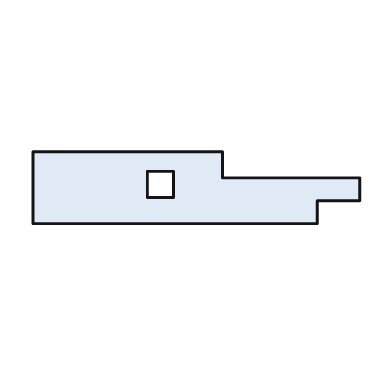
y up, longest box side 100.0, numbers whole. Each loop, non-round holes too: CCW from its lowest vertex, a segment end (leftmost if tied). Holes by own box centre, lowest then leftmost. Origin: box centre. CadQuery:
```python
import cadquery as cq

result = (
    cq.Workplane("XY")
    .moveTo(-50.0, -11.0)
    .lineTo(37.0, -11.0)
    .lineTo(37.0, -4.0)
    .lineTo(50.0, -4.0)
    .lineTo(50.0, 3.0)
    .lineTo(8.0, 3.0)
    .lineTo(8.0, 11.0)
    .lineTo(-50.0, 11.0)
    .close()
    .moveTo(-15.0, -3.0)
    .lineTo(-7.0, -3.0)
    .lineTo(-7.0, 5.0)
    .lineTo(-15.0, 5.0)
    .close()
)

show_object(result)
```